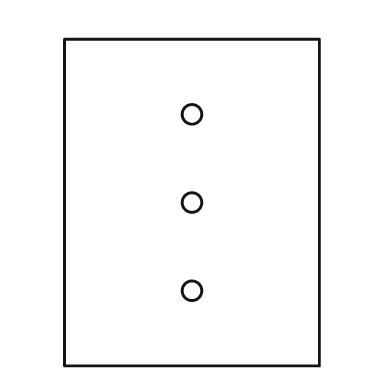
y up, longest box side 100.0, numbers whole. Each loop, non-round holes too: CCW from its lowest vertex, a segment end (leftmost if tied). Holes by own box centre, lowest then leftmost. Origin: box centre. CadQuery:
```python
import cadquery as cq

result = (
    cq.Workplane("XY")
    .moveTo(-39.0, -50.0)
    .lineTo(39.0, -50.0)
    .lineTo(39.0, 50.0)
    .lineTo(-39.0, 50.0)
    .close()
    .moveTo(0.0, -27.0)
    .circle(3.0)
    .moveTo(0.0, 0.0)
    .circle(3.0)
    .moveTo(0.0, 27.0)
    .circle(3.0)
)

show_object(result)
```